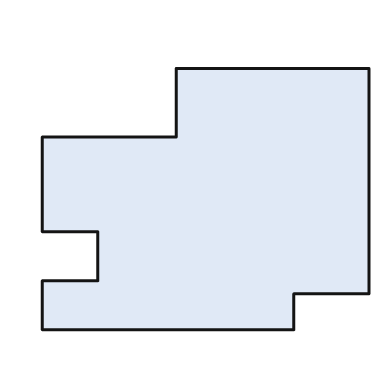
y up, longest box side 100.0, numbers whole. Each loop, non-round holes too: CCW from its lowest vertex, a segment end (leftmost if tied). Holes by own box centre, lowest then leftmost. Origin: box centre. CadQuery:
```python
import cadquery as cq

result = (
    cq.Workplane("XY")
    .moveTo(-50.0, -40.0)
    .lineTo(27.0, -40.0)
    .lineTo(27.0, -29.0)
    .lineTo(50.0, -29.0)
    .lineTo(50.0, 40.0)
    .lineTo(-9.0, 40.0)
    .lineTo(-9.0, 19.0)
    .lineTo(-50.0, 19.0)
    .lineTo(-50.0, -10.0)
    .lineTo(-33.0, -10.0)
    .lineTo(-33.0, -25.0)
    .lineTo(-50.0, -25.0)
    .close()
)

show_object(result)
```